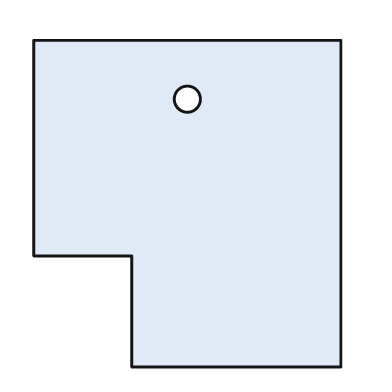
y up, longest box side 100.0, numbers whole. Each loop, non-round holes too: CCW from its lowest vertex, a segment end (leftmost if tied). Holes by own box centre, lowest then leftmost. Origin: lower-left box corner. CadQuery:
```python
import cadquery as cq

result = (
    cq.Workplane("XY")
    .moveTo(30.0, 0.0)
    .lineTo(94.0, 0.0)
    .lineTo(94.0, 100.0)
    .lineTo(0.0, 100.0)
    .lineTo(0.0, 34.0)
    .lineTo(30.0, 34.0)
    .close()
    .moveTo(47.0, 82.0)
    .circle(4.0)
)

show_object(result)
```